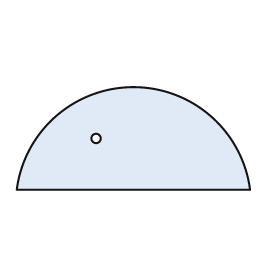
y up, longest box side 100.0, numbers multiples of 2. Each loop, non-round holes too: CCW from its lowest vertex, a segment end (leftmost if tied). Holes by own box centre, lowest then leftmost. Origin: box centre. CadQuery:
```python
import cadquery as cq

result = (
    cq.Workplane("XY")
    .moveTo(-50.0, -22.0)
    .lineTo(50.0, -22.0)
    .threePointArc((0.0, 22.0), (-50.0, -22.0))
    .close()
    .moveTo(-16.0, 0.0)
    .circle(2.0)
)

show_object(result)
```